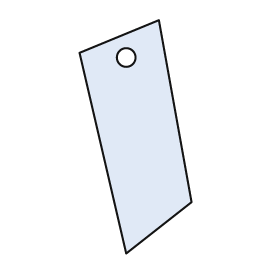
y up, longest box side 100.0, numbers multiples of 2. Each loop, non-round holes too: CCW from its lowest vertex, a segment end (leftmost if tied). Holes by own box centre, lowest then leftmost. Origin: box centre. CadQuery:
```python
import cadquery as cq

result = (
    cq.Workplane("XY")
    .moveTo(-4.0, -50.0)
    .lineTo(24.0, -28.0)
    .lineTo(10.0, 50.0)
    .lineTo(-24.0, 36.0)
    .close()
    .moveTo(-4.0, 34.0)
    .circle(4.0)
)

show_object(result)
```